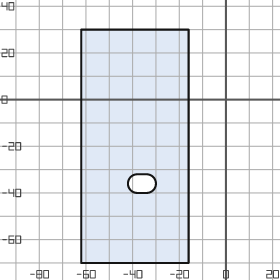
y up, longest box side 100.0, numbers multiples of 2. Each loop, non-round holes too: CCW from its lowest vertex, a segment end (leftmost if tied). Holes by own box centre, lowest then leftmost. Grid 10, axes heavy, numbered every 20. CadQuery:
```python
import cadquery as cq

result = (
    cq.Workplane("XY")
    .moveTo(-62.0, -70.0)
    .lineTo(-16.0, -70.0)
    .lineTo(-16.0, 30.0)
    .lineTo(-62.0, 30.0)
    .close()
    .moveTo(-38.0, -40.0)
    .lineTo(-34.0, -40.0)
    .threePointArc((-30.0, -36.0), (-34.0, -32.0))
    .lineTo(-38.0, -32.0)
    .threePointArc((-42.0, -36.0), (-38.0, -40.0))
    .close()
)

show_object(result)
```